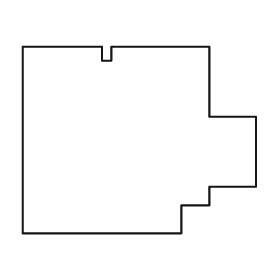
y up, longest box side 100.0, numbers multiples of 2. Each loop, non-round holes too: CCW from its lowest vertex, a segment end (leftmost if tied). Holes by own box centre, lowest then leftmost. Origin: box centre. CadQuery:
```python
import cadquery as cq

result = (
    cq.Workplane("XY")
    .moveTo(-50.0, -40.0)
    .lineTo(18.0, -40.0)
    .lineTo(18.0, -28.0)
    .lineTo(30.0, -28.0)
    .lineTo(30.0, -20.0)
    .lineTo(50.0, -20.0)
    .lineTo(50.0, 10.0)
    .lineTo(30.0, 10.0)
    .lineTo(30.0, 40.0)
    .lineTo(-12.0, 40.0)
    .lineTo(-12.0, 34.0)
    .lineTo(-16.0, 34.0)
    .lineTo(-16.0, 40.0)
    .lineTo(-50.0, 40.0)
    .close()
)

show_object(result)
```